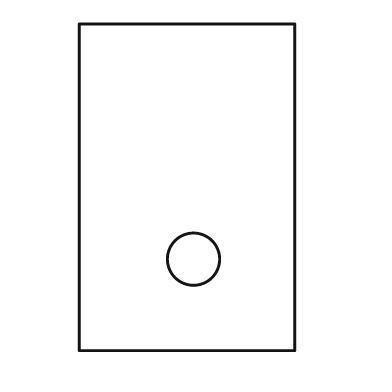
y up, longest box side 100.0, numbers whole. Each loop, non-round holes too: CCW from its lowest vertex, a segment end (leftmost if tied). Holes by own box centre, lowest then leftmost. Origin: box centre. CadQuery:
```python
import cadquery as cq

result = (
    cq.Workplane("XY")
    .moveTo(-33.0, -50.0)
    .lineTo(33.0, -50.0)
    .lineTo(33.0, 50.0)
    .lineTo(-33.0, 50.0)
    .close()
    .moveTo(2.0, -22.0)
    .circle(8.0)
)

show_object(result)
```